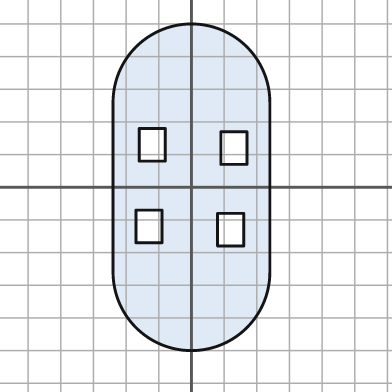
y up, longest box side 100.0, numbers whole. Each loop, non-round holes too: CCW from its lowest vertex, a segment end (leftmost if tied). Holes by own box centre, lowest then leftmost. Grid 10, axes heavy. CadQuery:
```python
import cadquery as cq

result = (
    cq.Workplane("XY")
    .moveTo(-24.0, -26.0)
    .threePointArc((0.0, -50.0), (24.0, -26.0))
    .lineTo(24.0, 26.0)
    .threePointArc((0.0, 50.0), (-24.0, 26.0))
    .close()
    .moveTo(8.0, -18.0)
    .lineTo(16.0, -18.0)
    .lineTo(16.0, -8.0)
    .lineTo(8.0, -8.0)
    .close()
    .moveTo(-17.0, -17.0)
    .lineTo(-9.0, -17.0)
    .lineTo(-9.0, -7.0)
    .lineTo(-17.0, -7.0)
    .close()
    .moveTo(9.0, 7.0)
    .lineTo(17.0, 7.0)
    .lineTo(17.0, 17.0)
    .lineTo(9.0, 17.0)
    .close()
    .moveTo(-16.0, 8.0)
    .lineTo(-8.0, 8.0)
    .lineTo(-8.0, 18.0)
    .lineTo(-16.0, 18.0)
    .close()
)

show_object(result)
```